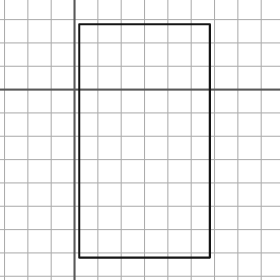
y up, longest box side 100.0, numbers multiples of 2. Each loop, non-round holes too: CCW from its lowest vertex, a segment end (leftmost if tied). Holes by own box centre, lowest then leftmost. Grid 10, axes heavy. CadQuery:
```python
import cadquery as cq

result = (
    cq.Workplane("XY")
    .moveTo(2.0, -72.0)
    .lineTo(58.0, -72.0)
    .lineTo(58.0, 28.0)
    .lineTo(2.0, 28.0)
    .close()
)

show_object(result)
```